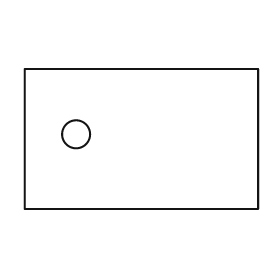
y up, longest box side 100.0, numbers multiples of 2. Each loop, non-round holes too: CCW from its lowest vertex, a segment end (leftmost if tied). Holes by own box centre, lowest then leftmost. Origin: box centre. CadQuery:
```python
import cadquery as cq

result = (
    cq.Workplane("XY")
    .moveTo(-50.0, -30.0)
    .lineTo(50.0, -30.0)
    .lineTo(50.0, 30.0)
    .lineTo(-50.0, 30.0)
    .close()
    .moveTo(-28.0, 2.0)
    .circle(6.0)
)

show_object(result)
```